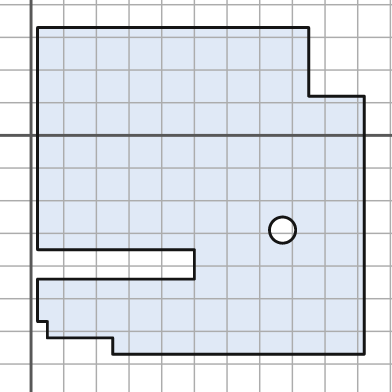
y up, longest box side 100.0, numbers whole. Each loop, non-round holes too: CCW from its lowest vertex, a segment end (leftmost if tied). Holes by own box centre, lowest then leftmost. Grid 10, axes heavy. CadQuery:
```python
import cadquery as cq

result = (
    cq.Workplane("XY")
    .moveTo(25.0, -67.0)
    .lineTo(102.0, -67.0)
    .lineTo(102.0, 12.0)
    .lineTo(85.0, 12.0)
    .lineTo(85.0, 33.0)
    .lineTo(2.0, 33.0)
    .lineTo(2.0, -35.0)
    .lineTo(50.0, -35.0)
    .lineTo(50.0, -44.0)
    .lineTo(2.0, -44.0)
    .lineTo(2.0, -57.0)
    .lineTo(5.0, -57.0)
    .lineTo(5.0, -62.0)
    .lineTo(25.0, -62.0)
    .close()
    .moveTo(77.0, -29.0)
    .circle(4.0)
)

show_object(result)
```